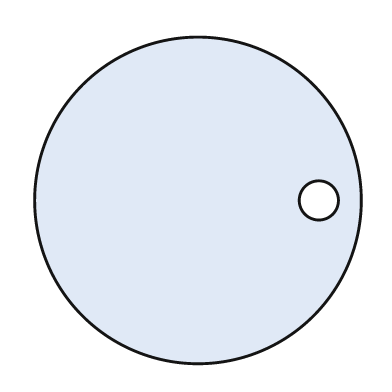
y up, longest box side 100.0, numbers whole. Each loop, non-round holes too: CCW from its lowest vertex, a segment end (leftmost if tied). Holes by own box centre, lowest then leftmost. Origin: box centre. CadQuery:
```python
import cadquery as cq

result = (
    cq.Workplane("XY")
    .moveTo(0.0, 0.0)
    .circle(50.0)
    .moveTo(37.0, 0.0)
    .circle(6.0)
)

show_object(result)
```